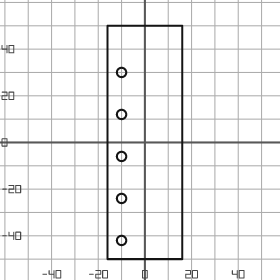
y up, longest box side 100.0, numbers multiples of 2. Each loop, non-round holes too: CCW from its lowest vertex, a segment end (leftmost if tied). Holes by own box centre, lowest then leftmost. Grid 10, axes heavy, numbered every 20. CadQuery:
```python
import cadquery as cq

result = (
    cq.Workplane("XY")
    .moveTo(-16.0, -50.0)
    .lineTo(16.0, -50.0)
    .lineTo(16.0, 50.0)
    .lineTo(-16.0, 50.0)
    .close()
    .moveTo(-10.0, -42.0)
    .circle(2.0)
    .moveTo(-10.0, -24.0)
    .circle(2.0)
    .moveTo(-10.0, -6.0)
    .circle(2.0)
    .moveTo(-10.0, 12.0)
    .circle(2.0)
    .moveTo(-10.0, 30.0)
    .circle(2.0)
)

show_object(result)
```